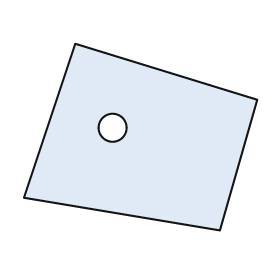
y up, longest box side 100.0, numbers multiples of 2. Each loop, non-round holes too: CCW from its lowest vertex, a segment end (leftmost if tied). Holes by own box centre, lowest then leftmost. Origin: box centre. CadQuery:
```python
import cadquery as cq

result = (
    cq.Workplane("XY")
    .moveTo(34.0, -40.0)
    .lineTo(50.0, 16.0)
    .lineTo(-28.0, 40.0)
    .lineTo(-50.0, -26.0)
    .close()
    .moveTo(-12.0, 4.0)
    .circle(6.0)
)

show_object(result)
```